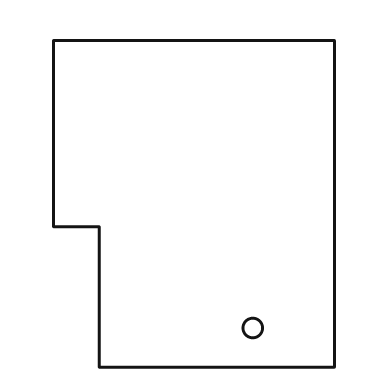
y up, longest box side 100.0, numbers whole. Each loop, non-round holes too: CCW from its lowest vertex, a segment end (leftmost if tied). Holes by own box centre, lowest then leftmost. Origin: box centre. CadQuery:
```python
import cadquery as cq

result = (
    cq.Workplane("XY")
    .moveTo(-29.0, -50.0)
    .lineTo(43.0, -50.0)
    .lineTo(43.0, 50.0)
    .lineTo(-43.0, 50.0)
    .lineTo(-43.0, -7.0)
    .lineTo(-29.0, -7.0)
    .close()
    .moveTo(18.0, -38.0)
    .circle(3.0)
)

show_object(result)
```